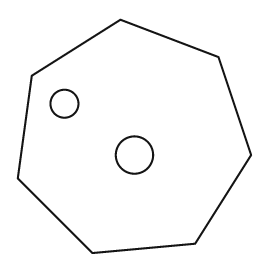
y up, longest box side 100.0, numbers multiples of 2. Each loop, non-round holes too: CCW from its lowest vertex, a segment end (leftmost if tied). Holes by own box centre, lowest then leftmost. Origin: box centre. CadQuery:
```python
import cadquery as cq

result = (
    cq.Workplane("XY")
    .moveTo(-18.0, -50.0)
    .lineTo(26.0, -46.0)
    .lineTo(50.0, -8.0)
    .lineTo(36.0, 34.0)
    .lineTo(-6.0, 50.0)
    .lineTo(-44.0, 26.0)
    .lineTo(-50.0, -18.0)
    .close()
    .moveTo(0.0, -8.0)
    .circle(8.0)
    .moveTo(-30.0, 14.0)
    .circle(6.0)
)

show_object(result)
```